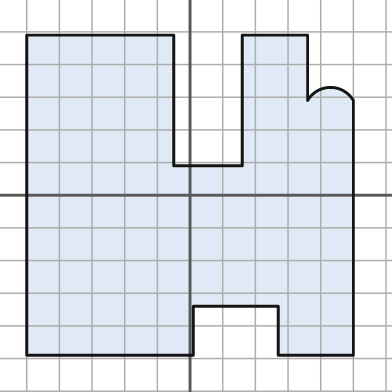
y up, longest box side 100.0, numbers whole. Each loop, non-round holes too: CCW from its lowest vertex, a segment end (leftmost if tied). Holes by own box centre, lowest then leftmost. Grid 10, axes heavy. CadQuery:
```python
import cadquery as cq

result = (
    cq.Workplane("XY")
    .moveTo(-50.0, -49.0)
    .lineTo(1.0, -49.0)
    .lineTo(1.0, -34.0)
    .lineTo(27.0, -34.0)
    .lineTo(27.0, -49.0)
    .lineTo(50.0, -49.0)
    .lineTo(50.0, 29.0)
    .threePointArc((43.0, 33.0), (36.0, 29.0))
    .lineTo(36.0, 49.0)
    .lineTo(16.0, 49.0)
    .lineTo(16.0, 9.0)
    .lineTo(-5.0, 9.0)
    .lineTo(-5.0, 49.0)
    .lineTo(-50.0, 49.0)
    .close()
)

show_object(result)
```